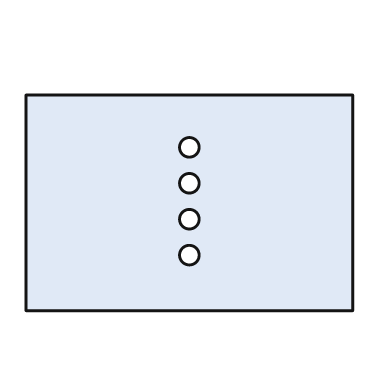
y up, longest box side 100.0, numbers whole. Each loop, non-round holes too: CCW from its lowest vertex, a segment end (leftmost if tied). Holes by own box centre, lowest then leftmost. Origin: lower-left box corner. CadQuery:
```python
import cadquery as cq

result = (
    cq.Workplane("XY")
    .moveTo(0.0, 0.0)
    .lineTo(100.0, 0.0)
    .lineTo(100.0, 66.0)
    .lineTo(0.0, 66.0)
    .close()
    .moveTo(50.0, 17.0)
    .circle(3.0)
    .moveTo(50.0, 28.0)
    .circle(3.0)
    .moveTo(50.0, 39.0)
    .circle(3.0)
    .moveTo(50.0, 50.0)
    .circle(3.0)
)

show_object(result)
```